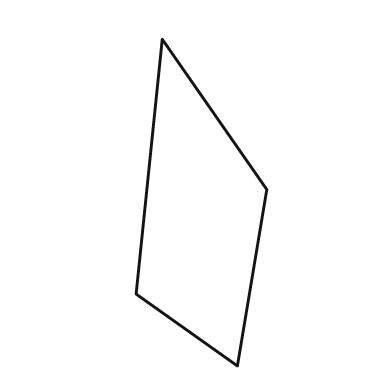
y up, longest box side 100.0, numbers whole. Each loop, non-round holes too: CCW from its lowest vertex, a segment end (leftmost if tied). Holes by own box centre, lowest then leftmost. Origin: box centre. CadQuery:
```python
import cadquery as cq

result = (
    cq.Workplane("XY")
    .moveTo(11.0, -50.0)
    .lineTo(20.0, 4.0)
    .lineTo(-12.0, 50.0)
    .lineTo(-20.0, -28.0)
    .close()
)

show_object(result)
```